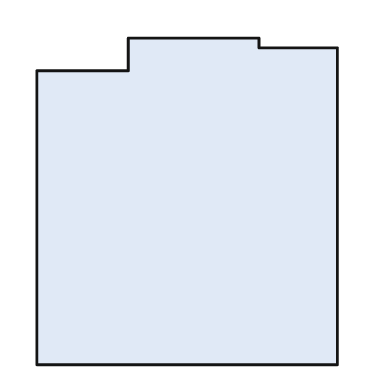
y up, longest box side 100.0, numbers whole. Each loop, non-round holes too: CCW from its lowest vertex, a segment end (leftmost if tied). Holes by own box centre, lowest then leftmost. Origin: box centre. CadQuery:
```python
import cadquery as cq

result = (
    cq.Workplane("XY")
    .moveTo(-46.0, -50.0)
    .lineTo(46.0, -50.0)
    .lineTo(46.0, 47.0)
    .lineTo(22.0, 47.0)
    .lineTo(22.0, 50.0)
    .lineTo(-18.0, 50.0)
    .lineTo(-18.0, 40.0)
    .lineTo(-46.0, 40.0)
    .close()
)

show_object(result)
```